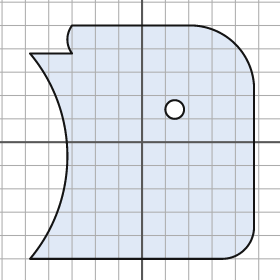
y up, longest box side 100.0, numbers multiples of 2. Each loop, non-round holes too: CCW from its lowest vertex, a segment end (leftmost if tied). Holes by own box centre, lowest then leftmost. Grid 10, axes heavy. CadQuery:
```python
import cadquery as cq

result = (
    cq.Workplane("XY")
    .moveTo(-48.0, -50.0)
    .lineTo(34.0, -50.0)
    .threePointArc((44.0, -46.0), (48.0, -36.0))
    .lineTo(48.0, 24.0)
    .threePointArc((40.0, 42.0), (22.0, 50.0))
    .lineTo(-30.0, 50.0)
    .threePointArc((-32.0, 44.0), (-30.0, 38.0))
    .lineTo(-48.0, 38.0)
    .threePointArc((-32.0, -6.0), (-48.0, -50.0))
    .close()
    .moveTo(14.0, 14.0)
    .circle(4.0)
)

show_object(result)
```